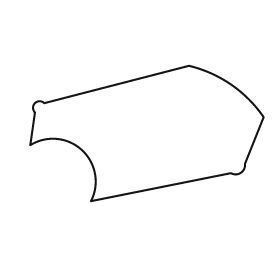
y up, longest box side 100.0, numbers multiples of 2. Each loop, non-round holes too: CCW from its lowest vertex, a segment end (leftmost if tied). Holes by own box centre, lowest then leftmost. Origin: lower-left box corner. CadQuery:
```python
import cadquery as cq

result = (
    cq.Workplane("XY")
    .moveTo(26.0, 0.0)
    .lineTo(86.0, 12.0)
    .threePointArc((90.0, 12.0), (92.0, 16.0))
    .lineTo(100.0, 36.0)
    .threePointArc((86.0, 50.0), (68.0, 58.0))
    .lineTo(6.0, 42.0)
    .threePointArc((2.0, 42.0), (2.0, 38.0))
    .lineTo(0.0, 24.0)
    .threePointArc((22.0, 22.0), (26.0, 0.0))
    .close()
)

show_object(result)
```